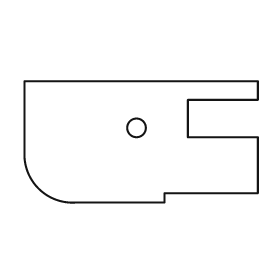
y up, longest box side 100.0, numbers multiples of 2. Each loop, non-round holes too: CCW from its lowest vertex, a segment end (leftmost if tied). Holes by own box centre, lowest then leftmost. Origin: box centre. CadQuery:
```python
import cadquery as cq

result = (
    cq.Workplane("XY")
    .moveTo(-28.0, -26.0)
    .lineTo(10.0, -26.0)
    .lineTo(10.0, -22.0)
    .lineTo(50.0, -22.0)
    .lineTo(50.0, 2.0)
    .lineTo(20.0, 2.0)
    .lineTo(20.0, 18.0)
    .lineTo(50.0, 18.0)
    .lineTo(50.0, 26.0)
    .lineTo(-50.0, 26.0)
    .lineTo(-50.0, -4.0)
    .threePointArc((-44.0, -20.0), (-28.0, -26.0))
    .close()
    .moveTo(-2.0, 6.0)
    .circle(4.0)
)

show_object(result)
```